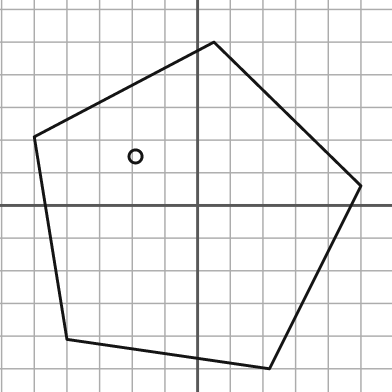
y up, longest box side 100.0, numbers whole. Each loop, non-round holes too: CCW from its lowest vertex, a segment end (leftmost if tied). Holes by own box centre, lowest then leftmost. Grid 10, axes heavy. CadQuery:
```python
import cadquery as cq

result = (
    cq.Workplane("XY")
    .moveTo(22.0, -50.0)
    .lineTo(50.0, 6.0)
    .lineTo(5.0, 50.0)
    .lineTo(-50.0, 21.0)
    .lineTo(-40.0, -41.0)
    .close()
    .moveTo(-19.0, 15.0)
    .circle(2.0)
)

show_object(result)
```